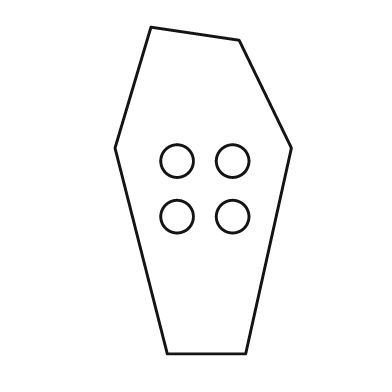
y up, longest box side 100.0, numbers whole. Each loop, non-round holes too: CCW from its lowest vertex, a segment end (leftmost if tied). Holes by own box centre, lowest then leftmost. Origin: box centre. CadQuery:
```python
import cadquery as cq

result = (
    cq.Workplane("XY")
    .moveTo(-11.0, -50.0)
    .lineTo(13.0, -50.0)
    .lineTo(27.0, 13.0)
    .lineTo(11.0, 46.0)
    .lineTo(-16.0, 50.0)
    .lineTo(-27.0, 13.0)
    .close()
    .moveTo(-8.0, -8.0)
    .circle(5.0)
    .moveTo(9.0, -8.0)
    .circle(5.0)
    .moveTo(-8.0, 9.0)
    .circle(5.0)
    .moveTo(9.0, 9.0)
    .circle(5.0)
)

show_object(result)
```